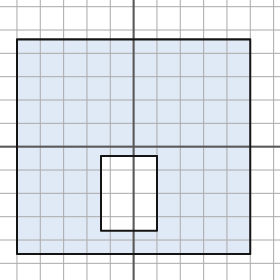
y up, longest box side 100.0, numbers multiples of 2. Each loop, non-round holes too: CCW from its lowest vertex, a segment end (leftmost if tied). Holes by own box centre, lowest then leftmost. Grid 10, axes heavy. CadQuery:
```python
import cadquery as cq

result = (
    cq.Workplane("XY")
    .moveTo(-50.0, -46.0)
    .lineTo(50.0, -46.0)
    .lineTo(50.0, 46.0)
    .lineTo(-50.0, 46.0)
    .close()
    .moveTo(-14.0, -36.0)
    .lineTo(10.0, -36.0)
    .lineTo(10.0, -4.0)
    .lineTo(-14.0, -4.0)
    .close()
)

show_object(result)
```